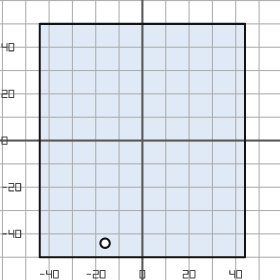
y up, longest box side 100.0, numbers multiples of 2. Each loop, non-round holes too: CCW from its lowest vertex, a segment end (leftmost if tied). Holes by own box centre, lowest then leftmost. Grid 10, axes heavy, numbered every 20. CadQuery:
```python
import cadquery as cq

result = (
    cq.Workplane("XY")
    .moveTo(-44.0, -50.0)
    .lineTo(44.0, -50.0)
    .lineTo(44.0, 50.0)
    .lineTo(-44.0, 50.0)
    .close()
    .moveTo(-16.0, -44.0)
    .circle(2.0)
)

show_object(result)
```